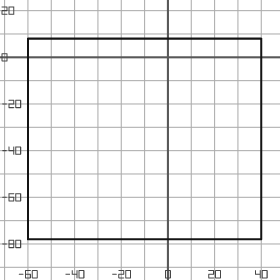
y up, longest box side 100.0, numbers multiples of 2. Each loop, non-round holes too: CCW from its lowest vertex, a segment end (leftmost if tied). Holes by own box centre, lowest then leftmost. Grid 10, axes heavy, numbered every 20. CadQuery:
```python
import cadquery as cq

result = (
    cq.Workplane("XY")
    .moveTo(-60.0, -78.0)
    .lineTo(40.0, -78.0)
    .lineTo(40.0, 8.0)
    .lineTo(-60.0, 8.0)
    .close()
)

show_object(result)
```